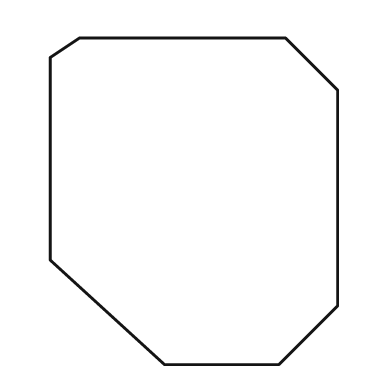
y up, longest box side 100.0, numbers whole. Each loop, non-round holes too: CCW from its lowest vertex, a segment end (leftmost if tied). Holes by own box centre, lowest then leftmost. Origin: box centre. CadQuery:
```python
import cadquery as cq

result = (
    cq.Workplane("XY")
    .moveTo(-9.0, -50.0)
    .lineTo(26.0, -50.0)
    .lineTo(44.0, -32.0)
    .lineTo(44.0, 34.0)
    .lineTo(28.0, 50.0)
    .lineTo(-35.0, 50.0)
    .lineTo(-44.0, 44.0)
    .lineTo(-44.0, -18.0)
    .close()
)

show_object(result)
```